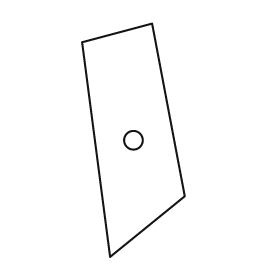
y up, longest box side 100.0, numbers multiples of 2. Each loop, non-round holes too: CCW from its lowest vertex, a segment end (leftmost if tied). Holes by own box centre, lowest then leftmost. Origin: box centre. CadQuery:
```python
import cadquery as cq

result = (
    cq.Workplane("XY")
    .moveTo(-10.0, -50.0)
    .lineTo(22.0, -24.0)
    .lineTo(8.0, 50.0)
    .lineTo(-22.0, 42.0)
    .close()
    .moveTo(0.0, 0.0)
    .circle(4.0)
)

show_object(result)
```